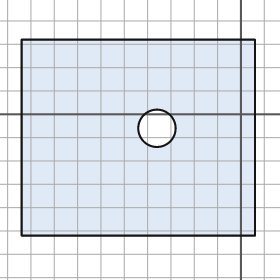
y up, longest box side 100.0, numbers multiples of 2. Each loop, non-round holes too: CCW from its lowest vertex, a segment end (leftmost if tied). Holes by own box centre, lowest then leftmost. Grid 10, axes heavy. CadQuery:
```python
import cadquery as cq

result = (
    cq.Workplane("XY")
    .moveTo(-94.0, -52.0)
    .lineTo(6.0, -52.0)
    .lineTo(6.0, 32.0)
    .lineTo(-94.0, 32.0)
    .close()
    .moveTo(-36.0, -6.0)
    .circle(8.0)
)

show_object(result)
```